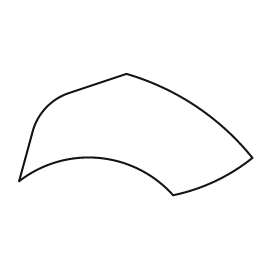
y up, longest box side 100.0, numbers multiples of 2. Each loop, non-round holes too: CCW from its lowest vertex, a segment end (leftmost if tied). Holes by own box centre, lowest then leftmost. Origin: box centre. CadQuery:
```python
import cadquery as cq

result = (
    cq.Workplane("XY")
    .moveTo(16.0, -26.0)
    .threePointArc((34.0, -20.0), (50.0, -10.0))
    .threePointArc((26.0, 12.0), (-4.0, 26.0))
    .lineTo(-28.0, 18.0)
    .threePointArc((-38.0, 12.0), (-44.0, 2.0))
    .lineTo(-50.0, -20.0)
    .threePointArc((-16.0, -10.0), (16.0, -26.0))
    .close()
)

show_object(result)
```